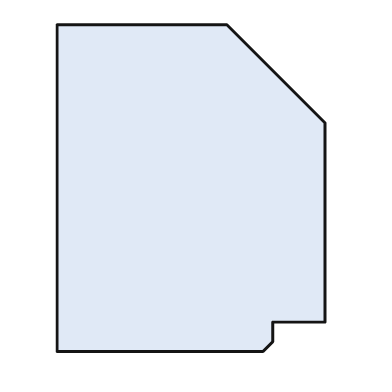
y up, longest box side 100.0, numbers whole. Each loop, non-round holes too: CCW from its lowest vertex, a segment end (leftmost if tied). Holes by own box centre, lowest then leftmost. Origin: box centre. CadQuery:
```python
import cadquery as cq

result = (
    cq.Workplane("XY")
    .moveTo(-41.0, -50.0)
    .lineTo(22.0, -50.0)
    .lineTo(25.0, -47.0)
    .lineTo(25.0, -41.0)
    .lineTo(41.0, -41.0)
    .lineTo(41.0, 20.0)
    .lineTo(11.0, 50.0)
    .lineTo(-41.0, 50.0)
    .close()
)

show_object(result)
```